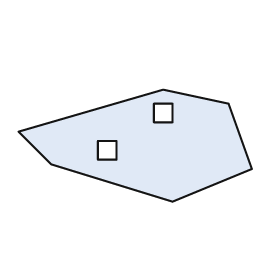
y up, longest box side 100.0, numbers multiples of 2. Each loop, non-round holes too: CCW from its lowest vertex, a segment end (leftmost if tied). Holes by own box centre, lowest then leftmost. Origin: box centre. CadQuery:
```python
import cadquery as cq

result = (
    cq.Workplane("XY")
    .moveTo(16.0, -24.0)
    .lineTo(50.0, -10.0)
    .lineTo(40.0, 18.0)
    .lineTo(12.0, 24.0)
    .lineTo(-50.0, 6.0)
    .lineTo(-36.0, -8.0)
    .close()
    .moveTo(-16.0, -6.0)
    .lineTo(-8.0, -6.0)
    .lineTo(-8.0, 2.0)
    .lineTo(-16.0, 2.0)
    .close()
    .moveTo(8.0, 10.0)
    .lineTo(16.0, 10.0)
    .lineTo(16.0, 18.0)
    .lineTo(8.0, 18.0)
    .close()
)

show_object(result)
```